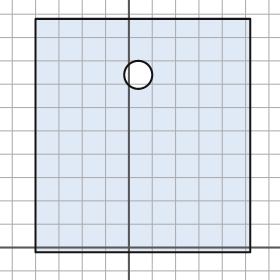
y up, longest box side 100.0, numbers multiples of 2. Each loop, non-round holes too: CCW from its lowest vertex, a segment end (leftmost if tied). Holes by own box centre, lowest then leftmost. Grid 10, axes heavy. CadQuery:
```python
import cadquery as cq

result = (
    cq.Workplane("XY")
    .moveTo(-40.0, -2.0)
    .lineTo(52.0, -2.0)
    .lineTo(52.0, 98.0)
    .lineTo(-40.0, 98.0)
    .close()
    .moveTo(4.0, 74.0)
    .circle(6.0)
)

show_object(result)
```